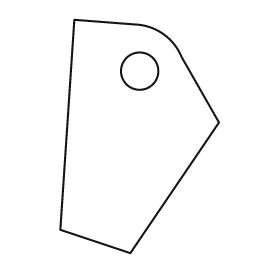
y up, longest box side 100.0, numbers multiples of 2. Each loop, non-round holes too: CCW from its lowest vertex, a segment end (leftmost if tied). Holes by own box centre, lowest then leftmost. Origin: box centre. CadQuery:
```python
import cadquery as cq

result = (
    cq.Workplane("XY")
    .moveTo(-4.0, -50.0)
    .lineTo(34.0, 6.0)
    .lineTo(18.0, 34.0)
    .threePointArc((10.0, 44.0), (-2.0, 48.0))
    .lineTo(-28.0, 50.0)
    .lineTo(-34.0, -40.0)
    .close()
    .moveTo(0.0, 28.0)
    .circle(8.0)
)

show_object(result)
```